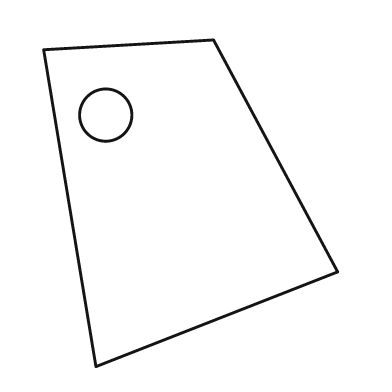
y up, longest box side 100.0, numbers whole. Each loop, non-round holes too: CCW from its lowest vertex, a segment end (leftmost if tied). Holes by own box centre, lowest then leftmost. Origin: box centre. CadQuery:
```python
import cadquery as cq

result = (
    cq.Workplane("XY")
    .moveTo(-29.0, -50.0)
    .lineTo(45.0, -21.0)
    .lineTo(7.0, 50.0)
    .lineTo(-45.0, 47.0)
    .close()
    .moveTo(-26.0, 27.0)
    .circle(8.0)
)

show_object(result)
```